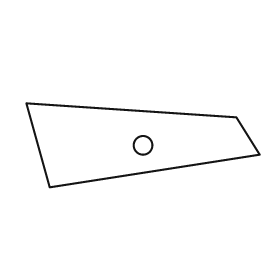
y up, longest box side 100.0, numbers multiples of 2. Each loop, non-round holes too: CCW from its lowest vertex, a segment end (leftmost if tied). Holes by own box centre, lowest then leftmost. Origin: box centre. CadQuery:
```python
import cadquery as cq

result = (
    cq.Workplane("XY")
    .moveTo(-40.0, -18.0)
    .lineTo(50.0, -4.0)
    .lineTo(40.0, 12.0)
    .lineTo(-50.0, 18.0)
    .close()
    .moveTo(0.0, 0.0)
    .circle(4.0)
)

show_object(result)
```